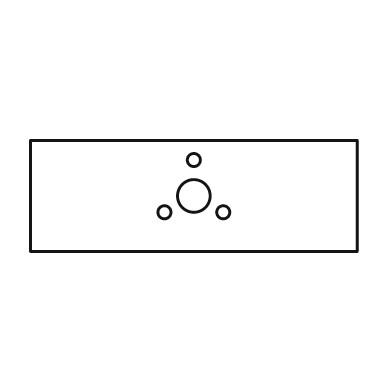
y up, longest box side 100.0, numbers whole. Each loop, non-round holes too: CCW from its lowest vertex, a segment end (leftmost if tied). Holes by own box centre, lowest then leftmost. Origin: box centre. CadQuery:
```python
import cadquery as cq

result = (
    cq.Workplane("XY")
    .moveTo(-50.0, -17.0)
    .lineTo(50.0, -17.0)
    .lineTo(50.0, 17.0)
    .lineTo(-50.0, 17.0)
    .close()
    .moveTo(-9.0, -5.0)
    .circle(2.0)
    .moveTo(9.0, -5.0)
    .circle(2.0)
    .moveTo(0.0, 0.0)
    .circle(5.0)
    .moveTo(0.0, 11.0)
    .circle(2.0)
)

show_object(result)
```